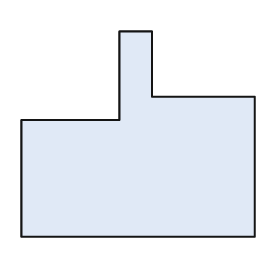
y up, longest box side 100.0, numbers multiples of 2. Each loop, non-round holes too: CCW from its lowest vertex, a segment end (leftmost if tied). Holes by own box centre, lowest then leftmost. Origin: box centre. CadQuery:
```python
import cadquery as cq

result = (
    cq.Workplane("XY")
    .moveTo(-50.0, -44.0)
    .lineTo(50.0, -44.0)
    .lineTo(50.0, 16.0)
    .lineTo(6.0, 16.0)
    .lineTo(6.0, 44.0)
    .lineTo(-8.0, 44.0)
    .lineTo(-8.0, 6.0)
    .lineTo(-50.0, 6.0)
    .close()
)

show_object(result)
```